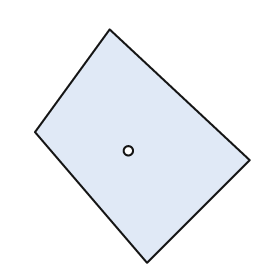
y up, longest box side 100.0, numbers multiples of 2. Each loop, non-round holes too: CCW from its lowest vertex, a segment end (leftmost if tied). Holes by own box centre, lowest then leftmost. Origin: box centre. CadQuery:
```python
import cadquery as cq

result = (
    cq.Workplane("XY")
    .moveTo(2.0, -50.0)
    .lineTo(46.0, -6.0)
    .lineTo(-14.0, 50.0)
    .lineTo(-46.0, 6.0)
    .close()
    .moveTo(-6.0, -2.0)
    .circle(2.0)
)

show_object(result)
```